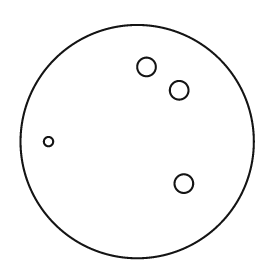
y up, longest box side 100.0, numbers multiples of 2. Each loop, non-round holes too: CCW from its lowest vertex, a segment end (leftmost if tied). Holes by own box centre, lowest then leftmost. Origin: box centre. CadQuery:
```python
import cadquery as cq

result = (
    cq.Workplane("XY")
    .moveTo(0.0, 0.0)
    .circle(50.0)
    .moveTo(20.0, -18.0)
    .circle(4.0)
    .moveTo(-38.0, 0.0)
    .circle(2.0)
    .moveTo(18.0, 22.0)
    .circle(4.0)
    .moveTo(4.0, 32.0)
    .circle(4.0)
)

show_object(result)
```